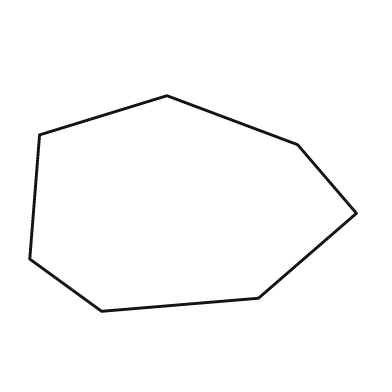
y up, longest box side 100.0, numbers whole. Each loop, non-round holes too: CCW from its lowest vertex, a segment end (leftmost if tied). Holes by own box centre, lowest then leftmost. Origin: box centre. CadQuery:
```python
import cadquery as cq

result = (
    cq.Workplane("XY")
    .moveTo(-28.0, -33.0)
    .lineTo(20.0, -29.0)
    .lineTo(50.0, -3.0)
    .lineTo(32.0, 18.0)
    .lineTo(-8.0, 33.0)
    .lineTo(-47.0, 21.0)
    .lineTo(-50.0, -17.0)
    .close()
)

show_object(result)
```